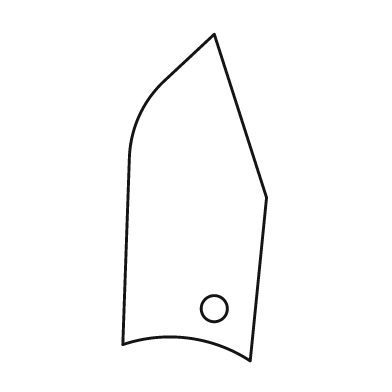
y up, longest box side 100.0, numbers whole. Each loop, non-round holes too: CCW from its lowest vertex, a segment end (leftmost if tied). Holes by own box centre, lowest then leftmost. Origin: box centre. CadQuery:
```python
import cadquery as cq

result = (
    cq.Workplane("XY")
    .moveTo(17.0, -50.0)
    .lineTo(22.0, 0.0)
    .lineTo(6.0, 50.0)
    .lineTo(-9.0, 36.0)
    .threePointArc((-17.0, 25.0), (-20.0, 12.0))
    .lineTo(-22.0, -45.0)
    .threePointArc((-2.0, -43.0), (17.0, -50.0))
    .close()
    .moveTo(6.0, -34.0)
    .circle(4.0)
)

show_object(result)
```